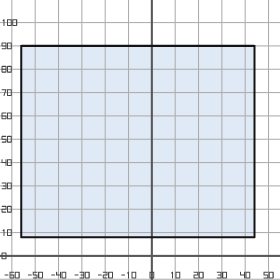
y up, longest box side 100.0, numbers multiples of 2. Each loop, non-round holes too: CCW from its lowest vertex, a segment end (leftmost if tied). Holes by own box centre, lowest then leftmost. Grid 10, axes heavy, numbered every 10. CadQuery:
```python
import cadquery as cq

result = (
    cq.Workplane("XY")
    .moveTo(-56.0, 8.0)
    .lineTo(44.0, 8.0)
    .lineTo(44.0, 90.0)
    .lineTo(-56.0, 90.0)
    .close()
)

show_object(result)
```